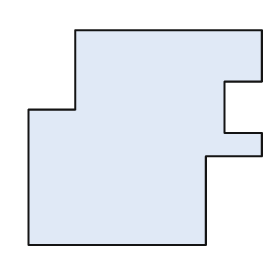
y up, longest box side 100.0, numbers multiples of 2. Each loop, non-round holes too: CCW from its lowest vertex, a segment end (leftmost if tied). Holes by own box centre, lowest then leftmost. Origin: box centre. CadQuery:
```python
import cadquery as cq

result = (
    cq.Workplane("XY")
    .moveTo(-50.0, -46.0)
    .lineTo(26.0, -46.0)
    .lineTo(26.0, -8.0)
    .lineTo(50.0, -8.0)
    .lineTo(50.0, 2.0)
    .lineTo(34.0, 2.0)
    .lineTo(34.0, 24.0)
    .lineTo(50.0, 24.0)
    .lineTo(50.0, 46.0)
    .lineTo(-30.0, 46.0)
    .lineTo(-30.0, 12.0)
    .lineTo(-50.0, 12.0)
    .close()
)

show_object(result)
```